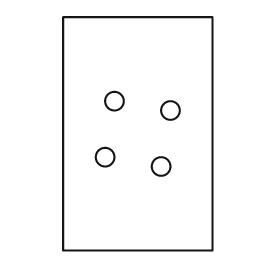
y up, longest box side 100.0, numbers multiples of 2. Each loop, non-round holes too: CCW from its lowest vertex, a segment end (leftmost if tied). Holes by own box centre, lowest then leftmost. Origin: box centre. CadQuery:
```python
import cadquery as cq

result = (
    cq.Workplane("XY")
    .moveTo(-32.0, -50.0)
    .lineTo(32.0, -50.0)
    .lineTo(32.0, 50.0)
    .lineTo(-32.0, 50.0)
    .close()
    .moveTo(10.0, -14.0)
    .circle(4.0)
    .moveTo(-14.0, -10.0)
    .circle(4.0)
    .moveTo(14.0, 10.0)
    .circle(4.0)
    .moveTo(-10.0, 14.0)
    .circle(4.0)
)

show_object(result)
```